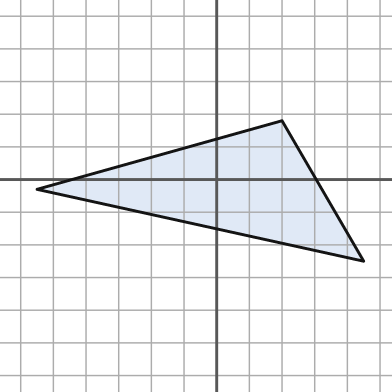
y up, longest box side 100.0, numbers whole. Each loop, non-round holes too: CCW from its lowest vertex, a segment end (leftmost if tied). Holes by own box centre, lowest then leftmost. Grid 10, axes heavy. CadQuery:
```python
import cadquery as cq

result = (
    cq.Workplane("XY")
    .moveTo(45.0, -25.0)
    .lineTo(20.0, 18.0)
    .lineTo(-55.0, -3.0)
    .close()
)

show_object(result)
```